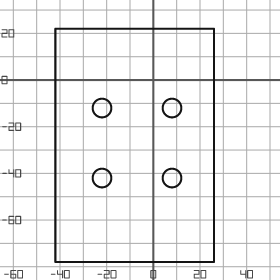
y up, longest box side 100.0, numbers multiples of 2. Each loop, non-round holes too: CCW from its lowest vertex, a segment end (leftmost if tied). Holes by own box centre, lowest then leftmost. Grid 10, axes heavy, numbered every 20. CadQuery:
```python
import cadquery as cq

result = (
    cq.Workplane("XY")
    .moveTo(-42.0, -78.0)
    .lineTo(26.0, -78.0)
    .lineTo(26.0, 22.0)
    .lineTo(-42.0, 22.0)
    .close()
    .moveTo(-22.0, -42.0)
    .circle(4.0)
    .moveTo(8.0, -42.0)
    .circle(4.0)
    .moveTo(-22.0, -12.0)
    .circle(4.0)
    .moveTo(8.0, -12.0)
    .circle(4.0)
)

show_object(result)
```